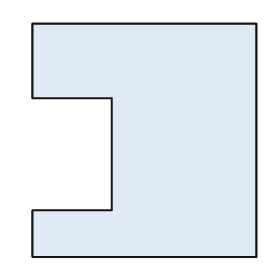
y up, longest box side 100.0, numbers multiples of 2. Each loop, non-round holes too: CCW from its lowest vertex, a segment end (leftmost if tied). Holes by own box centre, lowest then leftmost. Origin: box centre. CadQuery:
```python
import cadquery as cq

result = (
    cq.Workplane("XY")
    .moveTo(-48.0, -50.0)
    .lineTo(48.0, -50.0)
    .lineTo(48.0, 50.0)
    .lineTo(-48.0, 50.0)
    .lineTo(-48.0, 18.0)
    .lineTo(-14.0, 18.0)
    .lineTo(-14.0, -30.0)
    .lineTo(-48.0, -30.0)
    .close()
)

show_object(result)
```